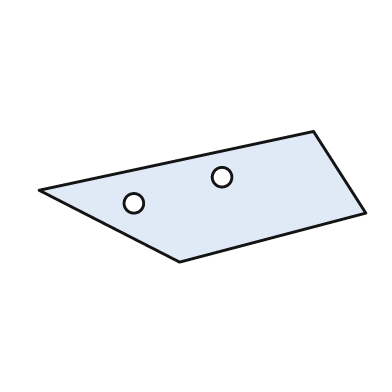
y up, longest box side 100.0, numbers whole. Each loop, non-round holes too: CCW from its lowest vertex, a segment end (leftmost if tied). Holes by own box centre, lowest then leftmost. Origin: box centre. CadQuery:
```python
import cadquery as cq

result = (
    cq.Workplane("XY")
    .moveTo(-7.0, -20.0)
    .lineTo(50.0, -5.0)
    .lineTo(34.0, 20.0)
    .lineTo(-50.0, 2.0)
    .close()
    .moveTo(-21.0, -2.0)
    .circle(3.0)
    .moveTo(6.0, 6.0)
    .circle(3.0)
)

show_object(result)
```